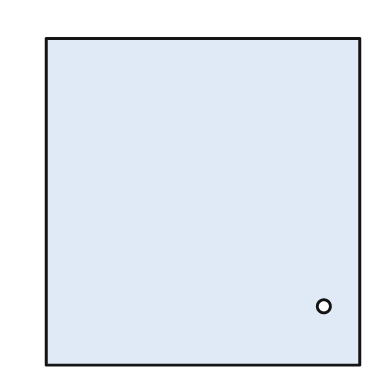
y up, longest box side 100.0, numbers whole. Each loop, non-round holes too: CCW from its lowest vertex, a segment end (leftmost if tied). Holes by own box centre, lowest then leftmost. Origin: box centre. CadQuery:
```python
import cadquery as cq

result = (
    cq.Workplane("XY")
    .moveTo(-48.0, -50.0)
    .lineTo(48.0, -50.0)
    .lineTo(48.0, 50.0)
    .lineTo(-48.0, 50.0)
    .close()
    .moveTo(37.0, -32.0)
    .circle(2.0)
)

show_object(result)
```